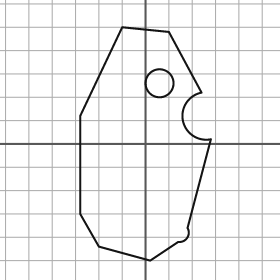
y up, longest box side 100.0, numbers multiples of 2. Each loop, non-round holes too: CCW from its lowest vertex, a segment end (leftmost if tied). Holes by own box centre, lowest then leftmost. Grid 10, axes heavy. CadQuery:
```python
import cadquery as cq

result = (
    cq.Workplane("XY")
    .moveTo(2.0, -50.0)
    .lineTo(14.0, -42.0)
    .threePointArc((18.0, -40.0), (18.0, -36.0))
    .lineTo(28.0, 2.0)
    .threePointArc((16.0, 10.0), (24.0, 22.0))
    .lineTo(10.0, 48.0)
    .lineTo(-10.0, 50.0)
    .lineTo(-28.0, 12.0)
    .lineTo(-28.0, -30.0)
    .lineTo(-20.0, -44.0)
    .close()
    .moveTo(6.0, 26.0)
    .circle(6.0)
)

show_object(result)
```